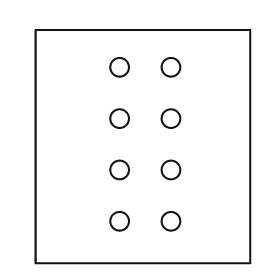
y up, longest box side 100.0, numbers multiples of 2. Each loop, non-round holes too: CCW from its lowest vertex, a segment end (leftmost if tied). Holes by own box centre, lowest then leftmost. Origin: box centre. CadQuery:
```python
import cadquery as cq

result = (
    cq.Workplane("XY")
    .moveTo(-46.0, -50.0)
    .lineTo(46.0, -50.0)
    .lineTo(46.0, 50.0)
    .lineTo(-46.0, 50.0)
    .close()
    .moveTo(-10.0, -32.0)
    .circle(4.0)
    .moveTo(12.0, -32.0)
    .circle(4.0)
    .moveTo(-10.0, -10.0)
    .circle(4.0)
    .moveTo(12.0, -10.0)
    .circle(4.0)
    .moveTo(-10.0, 12.0)
    .circle(4.0)
    .moveTo(12.0, 12.0)
    .circle(4.0)
    .moveTo(-10.0, 34.0)
    .circle(4.0)
    .moveTo(12.0, 34.0)
    .circle(4.0)
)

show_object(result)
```